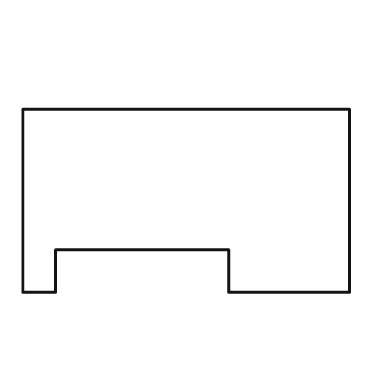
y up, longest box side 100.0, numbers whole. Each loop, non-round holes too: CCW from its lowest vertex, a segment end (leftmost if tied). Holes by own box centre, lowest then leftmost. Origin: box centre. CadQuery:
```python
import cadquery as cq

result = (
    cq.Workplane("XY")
    .moveTo(-50.0, -28.0)
    .lineTo(-40.0, -28.0)
    .lineTo(-40.0, -15.0)
    .lineTo(13.0, -15.0)
    .lineTo(13.0, -28.0)
    .lineTo(50.0, -28.0)
    .lineTo(50.0, 28.0)
    .lineTo(-50.0, 28.0)
    .close()
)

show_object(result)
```